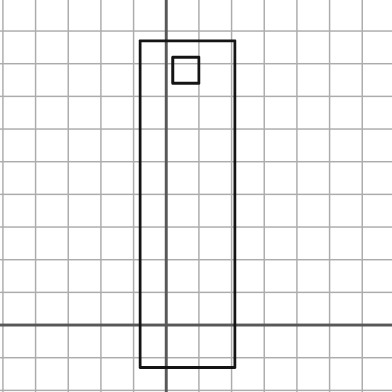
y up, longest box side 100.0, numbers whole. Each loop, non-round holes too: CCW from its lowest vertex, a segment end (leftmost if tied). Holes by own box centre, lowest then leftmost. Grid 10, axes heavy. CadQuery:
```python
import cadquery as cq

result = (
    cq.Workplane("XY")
    .moveTo(-8.0, -13.0)
    .lineTo(21.0, -13.0)
    .lineTo(21.0, 87.0)
    .lineTo(-8.0, 87.0)
    .close()
    .moveTo(2.0, 74.0)
    .lineTo(10.0, 74.0)
    .lineTo(10.0, 82.0)
    .lineTo(2.0, 82.0)
    .close()
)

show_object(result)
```